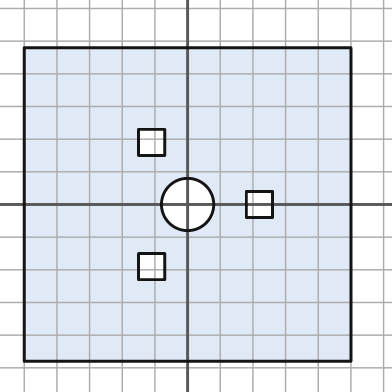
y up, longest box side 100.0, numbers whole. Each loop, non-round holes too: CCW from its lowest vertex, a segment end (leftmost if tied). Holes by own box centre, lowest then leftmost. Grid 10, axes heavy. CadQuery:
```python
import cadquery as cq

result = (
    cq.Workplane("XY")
    .moveTo(-50.0, -48.0)
    .lineTo(50.0, -48.0)
    .lineTo(50.0, 48.0)
    .lineTo(-50.0, 48.0)
    .close()
    .moveTo(-15.0, -23.0)
    .lineTo(-7.0, -23.0)
    .lineTo(-7.0, -15.0)
    .lineTo(-15.0, -15.0)
    .close()
    .moveTo(0.0, 0.0)
    .circle(8.0)
    .moveTo(18.0, -4.0)
    .lineTo(26.0, -4.0)
    .lineTo(26.0, 4.0)
    .lineTo(18.0, 4.0)
    .close()
    .moveTo(-15.0, 15.0)
    .lineTo(-7.0, 15.0)
    .lineTo(-7.0, 23.0)
    .lineTo(-15.0, 23.0)
    .close()
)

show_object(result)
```